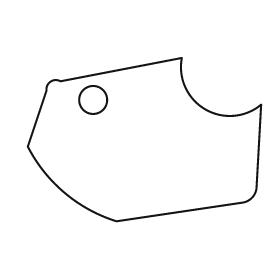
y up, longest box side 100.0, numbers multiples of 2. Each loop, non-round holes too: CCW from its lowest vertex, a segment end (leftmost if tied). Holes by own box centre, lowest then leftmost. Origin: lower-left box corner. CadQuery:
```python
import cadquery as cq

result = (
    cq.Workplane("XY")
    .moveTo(38.0, 0.0)
    .lineTo(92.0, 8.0)
    .threePointArc((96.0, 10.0), (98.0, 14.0))
    .lineTo(100.0, 50.0)
    .threePointArc((76.0, 48.0), (66.0, 70.0))
    .lineTo(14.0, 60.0)
    .threePointArc((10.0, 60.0), (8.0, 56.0))
    .lineTo(0.0, 32.0)
    .threePointArc((16.0, 12.0), (38.0, 0.0))
    .close()
    .moveTo(28.0, 52.0)
    .circle(6.0)
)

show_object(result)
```